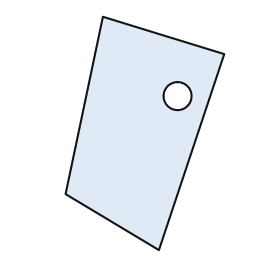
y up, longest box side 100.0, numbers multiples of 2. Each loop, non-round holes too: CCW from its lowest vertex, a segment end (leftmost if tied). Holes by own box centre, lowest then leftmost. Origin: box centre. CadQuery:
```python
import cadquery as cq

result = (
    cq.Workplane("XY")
    .moveTo(6.0, -50.0)
    .lineTo(34.0, 34.0)
    .lineTo(-18.0, 50.0)
    .lineTo(-34.0, -26.0)
    .close()
    .moveTo(14.0, 16.0)
    .circle(6.0)
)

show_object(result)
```